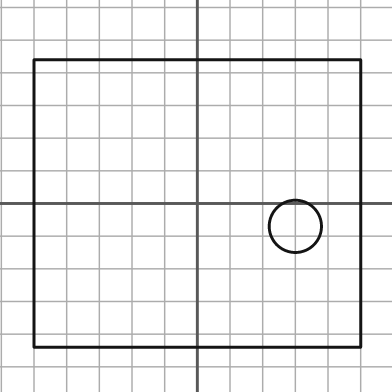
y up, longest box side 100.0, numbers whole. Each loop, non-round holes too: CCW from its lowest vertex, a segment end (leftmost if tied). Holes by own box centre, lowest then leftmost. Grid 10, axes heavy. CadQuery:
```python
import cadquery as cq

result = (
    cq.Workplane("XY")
    .moveTo(-50.0, -44.0)
    .lineTo(50.0, -44.0)
    .lineTo(50.0, 44.0)
    .lineTo(-50.0, 44.0)
    .close()
    .moveTo(30.0, -7.0)
    .circle(8.0)
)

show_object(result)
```